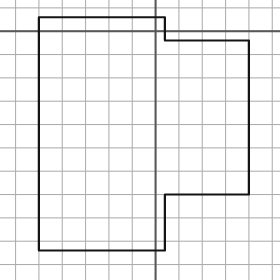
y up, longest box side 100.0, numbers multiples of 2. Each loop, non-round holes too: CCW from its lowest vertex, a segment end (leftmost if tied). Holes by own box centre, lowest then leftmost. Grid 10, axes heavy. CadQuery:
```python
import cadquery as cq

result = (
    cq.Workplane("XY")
    .moveTo(-50.0, -94.0)
    .lineTo(4.0, -94.0)
    .lineTo(4.0, -70.0)
    .lineTo(40.0, -70.0)
    .lineTo(40.0, -4.0)
    .lineTo(4.0, -4.0)
    .lineTo(4.0, 6.0)
    .lineTo(-50.0, 6.0)
    .close()
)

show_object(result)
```